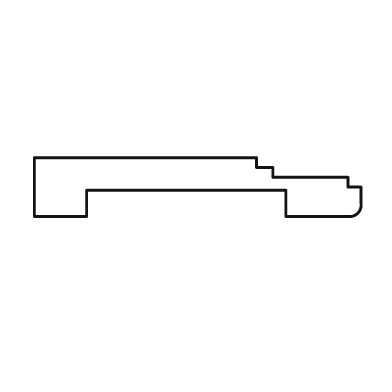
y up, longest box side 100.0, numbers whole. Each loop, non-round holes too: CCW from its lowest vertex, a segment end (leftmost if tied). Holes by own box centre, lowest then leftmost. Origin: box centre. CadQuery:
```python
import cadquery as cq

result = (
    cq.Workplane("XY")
    .moveTo(-50.0, -9.0)
    .lineTo(-34.0, -9.0)
    .lineTo(-34.0, -1.0)
    .lineTo(27.0, -1.0)
    .lineTo(27.0, -9.0)
    .lineTo(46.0, -9.0)
    .threePointArc((49.0, -8.0), (50.0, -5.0))
    .lineTo(50.0, 0.0)
    .lineTo(46.0, 0.0)
    .lineTo(46.0, 3.0)
    .lineTo(23.0, 3.0)
    .lineTo(23.0, 6.0)
    .lineTo(18.0, 6.0)
    .lineTo(18.0, 9.0)
    .lineTo(-50.0, 9.0)
    .close()
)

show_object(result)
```